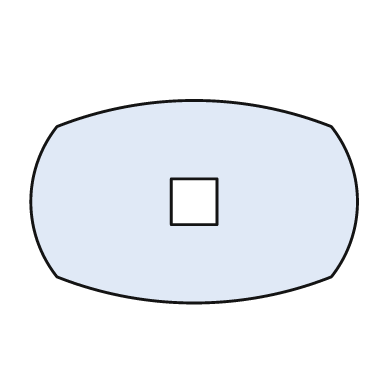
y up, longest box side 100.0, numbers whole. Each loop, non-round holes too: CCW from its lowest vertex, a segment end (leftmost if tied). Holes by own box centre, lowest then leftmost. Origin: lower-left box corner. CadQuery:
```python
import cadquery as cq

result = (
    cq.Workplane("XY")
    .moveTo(8.0, 8.0)
    .threePointArc((50.0, 0.0), (92.0, 8.0))
    .threePointArc((100.0, 31.0), (92.0, 54.0))
    .threePointArc((50.0, 62.0), (8.0, 54.0))
    .threePointArc((0.0, 31.0), (8.0, 8.0))
    .close()
    .moveTo(43.0, 24.0)
    .lineTo(57.0, 24.0)
    .lineTo(57.0, 38.0)
    .lineTo(43.0, 38.0)
    .close()
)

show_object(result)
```